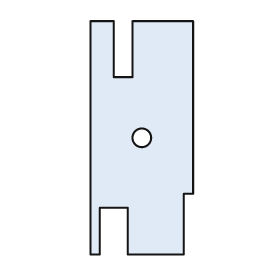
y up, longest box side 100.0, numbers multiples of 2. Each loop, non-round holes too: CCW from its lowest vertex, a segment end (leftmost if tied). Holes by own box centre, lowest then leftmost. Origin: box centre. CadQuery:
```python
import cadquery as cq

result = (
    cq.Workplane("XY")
    .moveTo(-22.0, -50.0)
    .lineTo(-18.0, -50.0)
    .lineTo(-18.0, -30.0)
    .lineTo(-6.0, -30.0)
    .lineTo(-6.0, -50.0)
    .lineTo(18.0, -50.0)
    .lineTo(18.0, -24.0)
    .lineTo(22.0, -24.0)
    .lineTo(22.0, 50.0)
    .lineTo(-4.0, 50.0)
    .lineTo(-4.0, 26.0)
    .lineTo(-12.0, 26.0)
    .lineTo(-12.0, 50.0)
    .lineTo(-22.0, 50.0)
    .close()
    .moveTo(0.0, 0.0)
    .circle(4.0)
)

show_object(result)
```